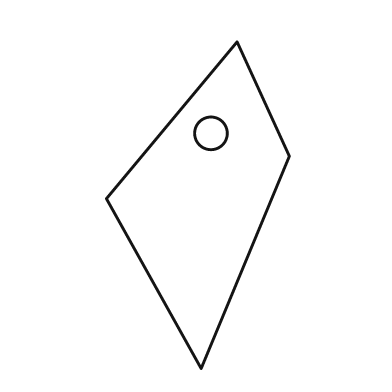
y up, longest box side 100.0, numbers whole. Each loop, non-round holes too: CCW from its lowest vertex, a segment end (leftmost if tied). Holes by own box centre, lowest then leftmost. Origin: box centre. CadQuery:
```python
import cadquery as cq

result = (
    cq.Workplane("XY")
    .moveTo(1.0, -50.0)
    .lineTo(28.0, 15.0)
    .lineTo(12.0, 50.0)
    .lineTo(-28.0, 2.0)
    .close()
    .moveTo(4.0, 22.0)
    .circle(5.0)
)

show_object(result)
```